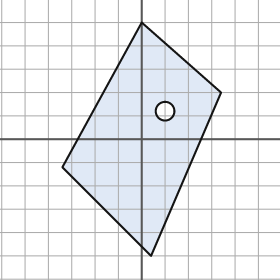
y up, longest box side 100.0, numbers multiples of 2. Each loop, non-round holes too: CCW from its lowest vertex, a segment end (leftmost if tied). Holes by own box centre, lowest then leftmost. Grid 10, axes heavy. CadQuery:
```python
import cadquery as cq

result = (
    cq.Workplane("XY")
    .moveTo(4.0, -50.0)
    .lineTo(34.0, 20.0)
    .lineTo(0.0, 50.0)
    .lineTo(-34.0, -12.0)
    .close()
    .moveTo(10.0, 12.0)
    .circle(4.0)
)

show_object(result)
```